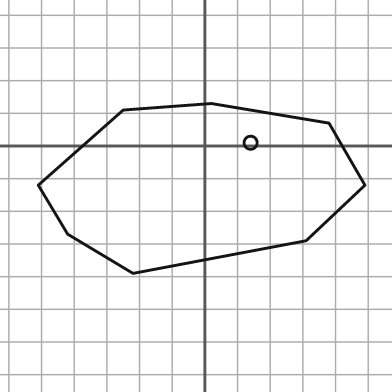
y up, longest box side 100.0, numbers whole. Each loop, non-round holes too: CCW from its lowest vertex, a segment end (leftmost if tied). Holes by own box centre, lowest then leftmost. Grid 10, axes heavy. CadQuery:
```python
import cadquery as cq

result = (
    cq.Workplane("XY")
    .moveTo(-22.0, -39.0)
    .lineTo(31.0, -29.0)
    .lineTo(49.0, -12.0)
    .lineTo(38.0, 7.0)
    .lineTo(2.0, 13.0)
    .lineTo(-25.0, 11.0)
    .lineTo(-51.0, -12.0)
    .lineTo(-42.0, -27.0)
    .close()
    .moveTo(14.0, 1.0)
    .circle(2.0)
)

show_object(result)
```